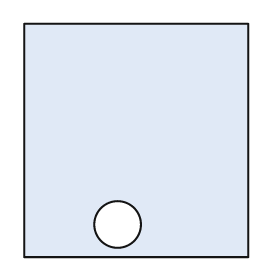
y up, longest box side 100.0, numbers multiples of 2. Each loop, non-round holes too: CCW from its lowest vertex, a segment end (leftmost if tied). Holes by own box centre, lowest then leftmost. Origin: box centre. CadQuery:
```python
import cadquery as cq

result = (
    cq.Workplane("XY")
    .moveTo(-48.0, -50.0)
    .lineTo(48.0, -50.0)
    .lineTo(48.0, 50.0)
    .lineTo(-48.0, 50.0)
    .close()
    .moveTo(-8.0, -36.0)
    .circle(10.0)
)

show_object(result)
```